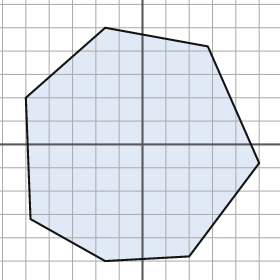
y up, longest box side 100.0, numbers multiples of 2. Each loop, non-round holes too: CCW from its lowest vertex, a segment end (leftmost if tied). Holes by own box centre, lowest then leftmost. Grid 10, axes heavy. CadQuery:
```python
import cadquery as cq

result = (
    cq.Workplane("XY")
    .moveTo(-16.0, -50.0)
    .lineTo(20.0, -48.0)
    .lineTo(50.0, -8.0)
    .lineTo(28.0, 42.0)
    .lineTo(-16.0, 50.0)
    .lineTo(-50.0, 20.0)
    .lineTo(-48.0, -32.0)
    .close()
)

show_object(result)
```